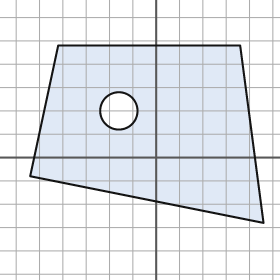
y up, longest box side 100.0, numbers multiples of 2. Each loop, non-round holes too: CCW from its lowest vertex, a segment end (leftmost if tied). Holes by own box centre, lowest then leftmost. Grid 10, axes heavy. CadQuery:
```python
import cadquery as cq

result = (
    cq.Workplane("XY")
    .moveTo(46.0, -28.0)
    .lineTo(36.0, 48.0)
    .lineTo(-42.0, 48.0)
    .lineTo(-54.0, -8.0)
    .close()
    .moveTo(-16.0, 20.0)
    .circle(8.0)
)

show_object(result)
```